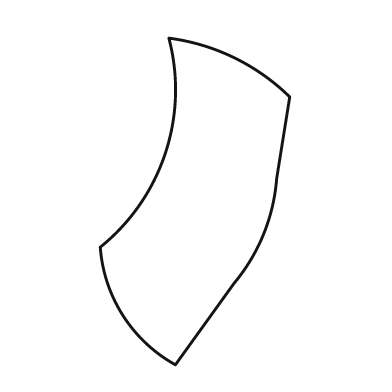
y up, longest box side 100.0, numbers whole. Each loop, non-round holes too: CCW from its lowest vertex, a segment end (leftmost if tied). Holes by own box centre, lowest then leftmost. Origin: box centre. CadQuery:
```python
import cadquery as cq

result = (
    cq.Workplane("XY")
    .moveTo(-6.0, -50.0)
    .lineTo(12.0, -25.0)
    .threePointArc((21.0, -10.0), (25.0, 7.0))
    .lineTo(29.0, 32.0)
    .threePointArc((12.0, 44.0), (-8.0, 50.0))
    .threePointArc((-9.0, 15.0), (-29.0, -14.0))
    .threePointArc((-22.0, -35.0), (-6.0, -50.0))
    .close()
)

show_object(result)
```